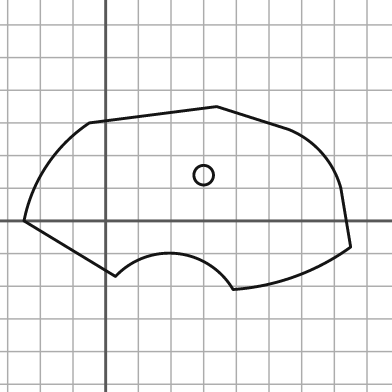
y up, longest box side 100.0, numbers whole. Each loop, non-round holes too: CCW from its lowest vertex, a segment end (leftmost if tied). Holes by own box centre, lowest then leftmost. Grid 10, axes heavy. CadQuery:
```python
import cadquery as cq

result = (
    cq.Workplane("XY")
    .moveTo(39.0, -21.0)
    .threePointArc((58.0, -17.0), (75.0, -8.0))
    .lineTo(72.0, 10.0)
    .threePointArc((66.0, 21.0), (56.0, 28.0))
    .lineTo(34.0, 35.0)
    .lineTo(-5.0, 30.0)
    .threePointArc((-18.0, 17.0), (-25.0, 0.0))
    .lineTo(3.0, -17.0)
    .threePointArc((22.0, -10.0), (39.0, -21.0))
    .close()
    .moveTo(30.0, 14.0)
    .circle(3.0)
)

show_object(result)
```